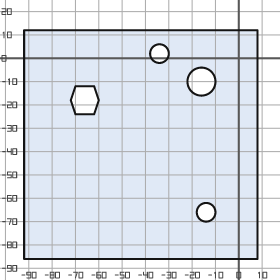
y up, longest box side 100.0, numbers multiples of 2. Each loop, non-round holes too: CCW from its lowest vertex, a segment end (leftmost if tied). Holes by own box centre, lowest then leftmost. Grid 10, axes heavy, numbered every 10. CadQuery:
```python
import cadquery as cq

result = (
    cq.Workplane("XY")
    .moveTo(-92.0, -86.0)
    .lineTo(8.0, -86.0)
    .lineTo(8.0, 12.0)
    .lineTo(-92.0, 12.0)
    .close()
    .moveTo(-14.0, -66.0)
    .circle(4.0)
    .moveTo(-70.0, -24.0)
    .lineTo(-62.0, -24.0)
    .lineTo(-60.0, -18.0)
    .lineTo(-62.0, -12.0)
    .lineTo(-70.0, -12.0)
    .lineTo(-72.0, -18.0)
    .close()
    .moveTo(-16.0, -10.0)
    .circle(6.0)
    .moveTo(-34.0, 2.0)
    .circle(4.0)
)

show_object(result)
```